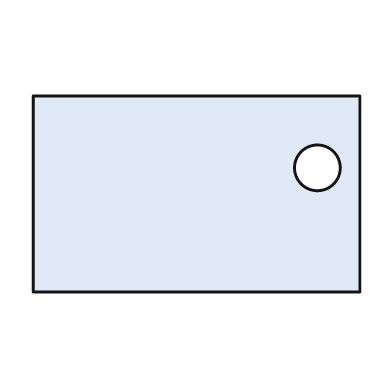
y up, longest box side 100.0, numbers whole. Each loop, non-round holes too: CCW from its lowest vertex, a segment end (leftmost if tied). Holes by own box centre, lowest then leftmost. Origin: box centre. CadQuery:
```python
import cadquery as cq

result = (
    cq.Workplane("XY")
    .moveTo(-50.0, -30.0)
    .lineTo(50.0, -30.0)
    .lineTo(50.0, 30.0)
    .lineTo(-50.0, 30.0)
    .close()
    .moveTo(37.0, 8.0)
    .circle(7.0)
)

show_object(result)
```